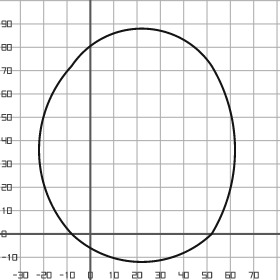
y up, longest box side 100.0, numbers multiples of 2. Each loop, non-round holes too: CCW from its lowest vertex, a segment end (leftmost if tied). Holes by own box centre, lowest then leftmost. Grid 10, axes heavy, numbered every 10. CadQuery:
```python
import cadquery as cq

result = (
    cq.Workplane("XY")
    .moveTo(-8.0, 0.0)
    .threePointArc((22.0, -12.0), (52.0, 0.0))
    .threePointArc((62.0, 36.0), (52.0, 72.0))
    .threePointArc((22.0, 88.0), (-8.0, 72.0))
    .threePointArc((-22.0, 36.0), (-8.0, 0.0))
    .close()
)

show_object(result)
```